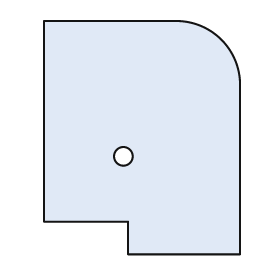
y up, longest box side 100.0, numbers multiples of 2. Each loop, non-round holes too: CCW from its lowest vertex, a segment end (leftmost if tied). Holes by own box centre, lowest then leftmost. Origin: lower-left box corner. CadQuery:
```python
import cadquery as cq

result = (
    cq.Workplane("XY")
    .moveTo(36.0, 0.0)
    .lineTo(84.0, 0.0)
    .lineTo(84.0, 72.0)
    .threePointArc((76.0, 92.0), (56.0, 100.0))
    .lineTo(0.0, 100.0)
    .lineTo(0.0, 14.0)
    .lineTo(36.0, 14.0)
    .close()
    .moveTo(34.0, 42.0)
    .circle(4.0)
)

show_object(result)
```